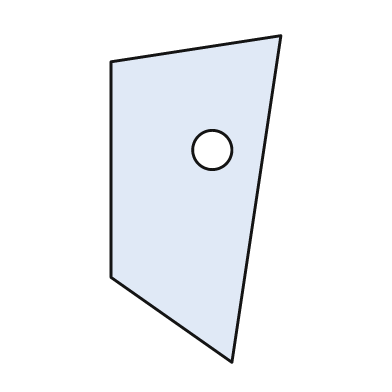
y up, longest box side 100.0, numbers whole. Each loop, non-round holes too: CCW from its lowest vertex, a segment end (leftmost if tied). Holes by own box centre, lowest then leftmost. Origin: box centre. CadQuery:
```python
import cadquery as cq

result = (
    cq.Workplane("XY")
    .moveTo(11.0, -50.0)
    .lineTo(26.0, 50.0)
    .lineTo(-26.0, 42.0)
    .lineTo(-26.0, -24.0)
    .close()
    .moveTo(5.0, 15.0)
    .circle(6.0)
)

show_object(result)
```